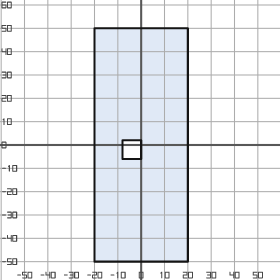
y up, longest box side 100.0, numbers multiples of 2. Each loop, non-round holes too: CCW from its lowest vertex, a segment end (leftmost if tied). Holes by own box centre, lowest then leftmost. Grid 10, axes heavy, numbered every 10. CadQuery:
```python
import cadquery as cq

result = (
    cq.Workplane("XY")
    .moveTo(-20.0, -50.0)
    .lineTo(20.0, -50.0)
    .lineTo(20.0, 50.0)
    .lineTo(-20.0, 50.0)
    .close()
    .moveTo(-8.0, -6.0)
    .lineTo(0.0, -6.0)
    .lineTo(0.0, 2.0)
    .lineTo(-8.0, 2.0)
    .close()
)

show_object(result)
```